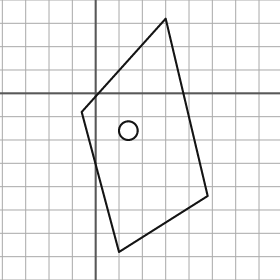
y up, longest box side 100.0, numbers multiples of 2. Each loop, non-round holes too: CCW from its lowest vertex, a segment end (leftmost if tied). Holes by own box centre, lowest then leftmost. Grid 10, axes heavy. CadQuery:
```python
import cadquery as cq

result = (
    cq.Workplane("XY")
    .moveTo(10.0, -68.0)
    .lineTo(48.0, -44.0)
    .lineTo(30.0, 32.0)
    .lineTo(-6.0, -8.0)
    .close()
    .moveTo(14.0, -16.0)
    .circle(4.0)
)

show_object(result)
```